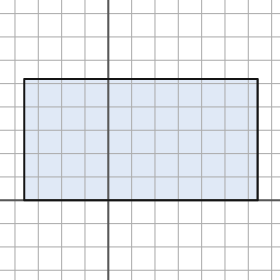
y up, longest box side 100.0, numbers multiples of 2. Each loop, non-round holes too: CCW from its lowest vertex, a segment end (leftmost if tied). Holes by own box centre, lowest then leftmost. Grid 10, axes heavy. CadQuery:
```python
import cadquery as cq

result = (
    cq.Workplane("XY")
    .moveTo(-36.0, 0.0)
    .lineTo(64.0, 0.0)
    .lineTo(64.0, 52.0)
    .lineTo(-36.0, 52.0)
    .close()
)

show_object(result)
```